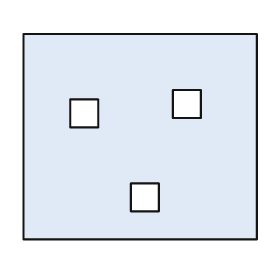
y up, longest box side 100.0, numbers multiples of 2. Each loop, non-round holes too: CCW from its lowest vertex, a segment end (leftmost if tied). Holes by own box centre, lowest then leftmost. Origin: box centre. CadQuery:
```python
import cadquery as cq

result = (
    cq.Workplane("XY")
    .moveTo(-50.0, -44.0)
    .lineTo(50.0, -44.0)
    .lineTo(50.0, 44.0)
    .lineTo(-50.0, 44.0)
    .close()
    .moveTo(-4.0, -32.0)
    .lineTo(8.0, -32.0)
    .lineTo(8.0, -20.0)
    .lineTo(-4.0, -20.0)
    .close()
    .moveTo(-30.0, 4.0)
    .lineTo(-18.0, 4.0)
    .lineTo(-18.0, 16.0)
    .lineTo(-30.0, 16.0)
    .close()
    .moveTo(14.0, 8.0)
    .lineTo(26.0, 8.0)
    .lineTo(26.0, 20.0)
    .lineTo(14.0, 20.0)
    .close()
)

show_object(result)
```